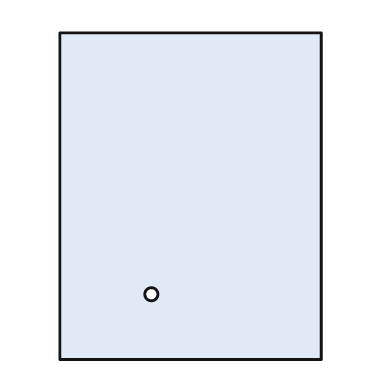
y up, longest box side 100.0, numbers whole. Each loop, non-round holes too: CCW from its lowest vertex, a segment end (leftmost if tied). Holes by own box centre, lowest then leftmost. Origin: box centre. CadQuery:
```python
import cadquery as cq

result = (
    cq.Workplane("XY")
    .moveTo(-40.0, -50.0)
    .lineTo(40.0, -50.0)
    .lineTo(40.0, 50.0)
    .lineTo(-40.0, 50.0)
    .close()
    .moveTo(-12.0, -30.0)
    .circle(2.0)
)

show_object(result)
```